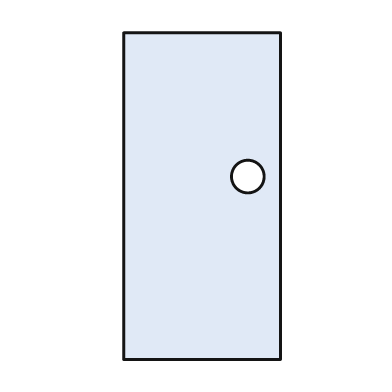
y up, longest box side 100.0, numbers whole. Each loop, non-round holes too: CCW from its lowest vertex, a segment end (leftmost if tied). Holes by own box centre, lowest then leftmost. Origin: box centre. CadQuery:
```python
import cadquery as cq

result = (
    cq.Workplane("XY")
    .moveTo(-24.0, -50.0)
    .lineTo(24.0, -50.0)
    .lineTo(24.0, 50.0)
    .lineTo(-24.0, 50.0)
    .close()
    .moveTo(14.0, 6.0)
    .circle(5.0)
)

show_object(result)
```